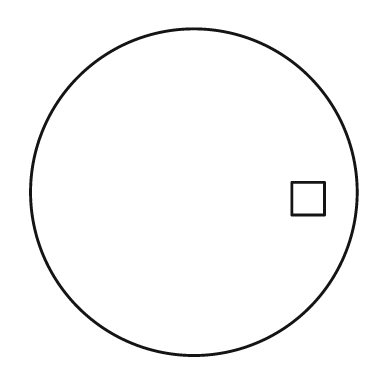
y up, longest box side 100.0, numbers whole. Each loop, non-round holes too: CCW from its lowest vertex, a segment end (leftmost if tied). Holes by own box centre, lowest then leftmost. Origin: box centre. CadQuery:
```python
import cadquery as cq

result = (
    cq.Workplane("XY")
    .moveTo(0.0, 0.0)
    .circle(50.0)
    .moveTo(30.0, -7.0)
    .lineTo(40.0, -7.0)
    .lineTo(40.0, 3.0)
    .lineTo(30.0, 3.0)
    .close()
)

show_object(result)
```